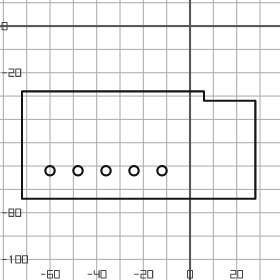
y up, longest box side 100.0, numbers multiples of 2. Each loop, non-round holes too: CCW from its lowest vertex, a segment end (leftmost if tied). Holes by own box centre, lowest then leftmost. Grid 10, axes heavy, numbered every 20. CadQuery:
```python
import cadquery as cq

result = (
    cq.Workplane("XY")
    .moveTo(-72.0, -74.0)
    .lineTo(28.0, -74.0)
    .lineTo(28.0, -32.0)
    .lineTo(6.0, -32.0)
    .lineTo(6.0, -28.0)
    .lineTo(-72.0, -28.0)
    .close()
    .moveTo(-60.0, -62.0)
    .circle(2.0)
    .moveTo(-48.0, -62.0)
    .circle(2.0)
    .moveTo(-36.0, -62.0)
    .circle(2.0)
    .moveTo(-24.0, -62.0)
    .circle(2.0)
    .moveTo(-12.0, -62.0)
    .circle(2.0)
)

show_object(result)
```